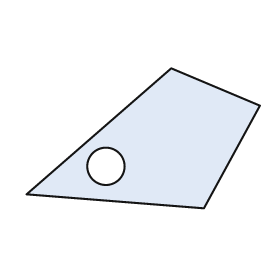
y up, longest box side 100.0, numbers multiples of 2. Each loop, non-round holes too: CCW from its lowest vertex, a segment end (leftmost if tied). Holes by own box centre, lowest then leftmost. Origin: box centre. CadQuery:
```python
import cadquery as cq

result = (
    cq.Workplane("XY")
    .moveTo(26.0, -30.0)
    .lineTo(50.0, 14.0)
    .lineTo(12.0, 30.0)
    .lineTo(-50.0, -24.0)
    .close()
    .moveTo(-16.0, -12.0)
    .circle(8.0)
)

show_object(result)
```